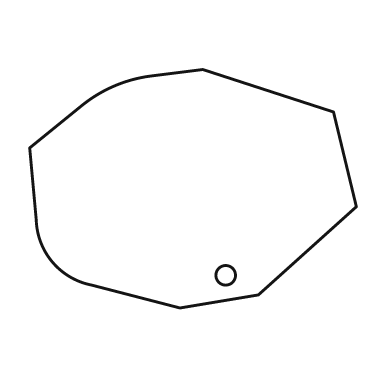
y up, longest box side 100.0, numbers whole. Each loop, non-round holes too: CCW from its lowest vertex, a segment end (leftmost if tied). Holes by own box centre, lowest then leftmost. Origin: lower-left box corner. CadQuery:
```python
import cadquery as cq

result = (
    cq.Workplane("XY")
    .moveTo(46.0, 0.0)
    .lineTo(70.0, 4.0)
    .lineTo(100.0, 31.0)
    .lineTo(93.0, 60.0)
    .lineTo(53.0, 73.0)
    .lineTo(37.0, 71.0)
    .threePointArc((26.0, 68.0), (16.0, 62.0))
    .lineTo(0.0, 49.0)
    .lineTo(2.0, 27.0)
    .threePointArc((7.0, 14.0), (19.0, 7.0))
    .close()
    .moveTo(60.0, 10.0)
    .circle(3.0)
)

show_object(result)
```